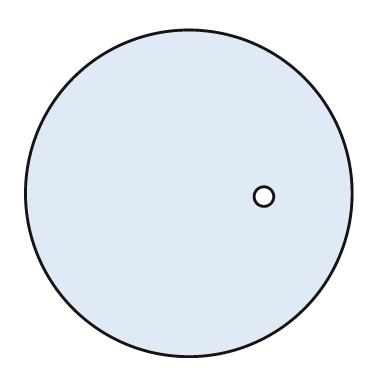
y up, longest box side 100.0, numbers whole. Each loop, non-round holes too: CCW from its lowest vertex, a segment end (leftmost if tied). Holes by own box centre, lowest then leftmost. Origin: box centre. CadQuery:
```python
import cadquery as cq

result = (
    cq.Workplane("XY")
    .moveTo(0.0, 0.0)
    .circle(50.0)
    .moveTo(23.0, -1.0)
    .circle(3.0)
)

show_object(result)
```